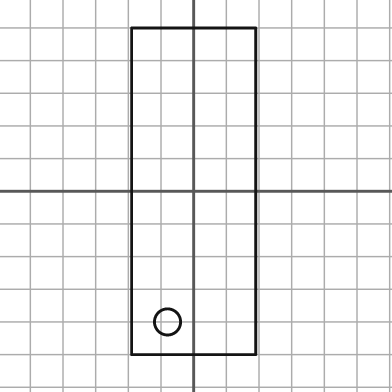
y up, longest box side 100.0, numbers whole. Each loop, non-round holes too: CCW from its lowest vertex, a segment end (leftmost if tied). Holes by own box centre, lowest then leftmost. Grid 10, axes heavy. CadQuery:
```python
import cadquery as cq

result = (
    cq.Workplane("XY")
    .moveTo(-19.0, -50.0)
    .lineTo(19.0, -50.0)
    .lineTo(19.0, 50.0)
    .lineTo(-19.0, 50.0)
    .close()
    .moveTo(-8.0, -40.0)
    .circle(4.0)
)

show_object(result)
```